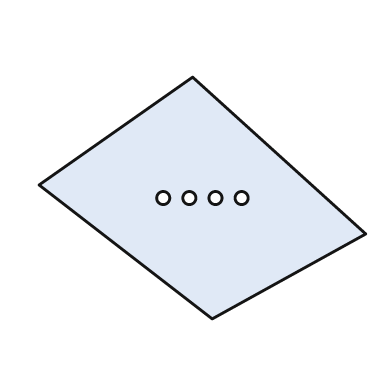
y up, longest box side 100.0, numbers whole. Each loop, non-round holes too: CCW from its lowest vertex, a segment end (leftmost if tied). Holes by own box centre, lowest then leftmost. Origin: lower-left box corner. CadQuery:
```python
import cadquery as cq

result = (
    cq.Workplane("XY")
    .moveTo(53.0, 0.0)
    .lineTo(100.0, 26.0)
    .lineTo(47.0, 74.0)
    .lineTo(0.0, 41.0)
    .close()
    .moveTo(38.0, 37.0)
    .circle(2.0)
    .moveTo(46.0, 37.0)
    .circle(2.0)
    .moveTo(54.0, 37.0)
    .circle(2.0)
    .moveTo(62.0, 37.0)
    .circle(2.0)
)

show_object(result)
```